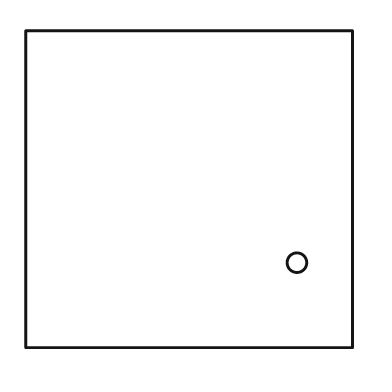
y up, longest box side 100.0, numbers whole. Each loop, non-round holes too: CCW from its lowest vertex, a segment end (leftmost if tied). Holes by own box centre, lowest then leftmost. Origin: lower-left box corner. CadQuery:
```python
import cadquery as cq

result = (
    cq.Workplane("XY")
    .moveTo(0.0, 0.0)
    .lineTo(100.0, 0.0)
    .lineTo(100.0, 97.0)
    .lineTo(0.0, 97.0)
    .close()
    .moveTo(83.0, 26.0)
    .circle(3.0)
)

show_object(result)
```